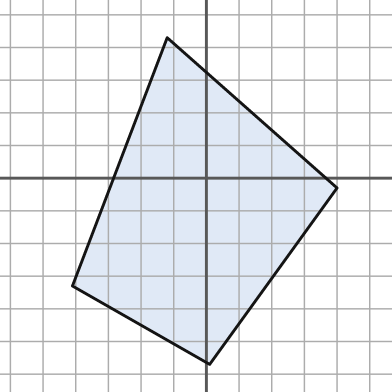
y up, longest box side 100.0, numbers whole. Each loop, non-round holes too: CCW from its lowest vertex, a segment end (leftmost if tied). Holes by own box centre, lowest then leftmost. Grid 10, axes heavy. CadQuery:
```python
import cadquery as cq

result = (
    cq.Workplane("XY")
    .moveTo(1.0, -57.0)
    .lineTo(40.0, -3.0)
    .lineTo(-12.0, 43.0)
    .lineTo(-41.0, -33.0)
    .close()
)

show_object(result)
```